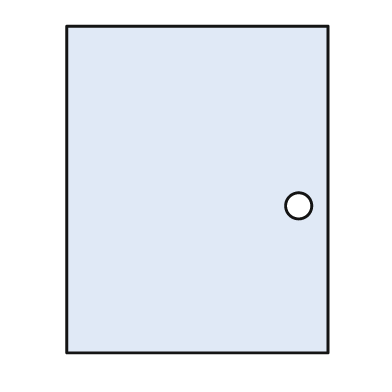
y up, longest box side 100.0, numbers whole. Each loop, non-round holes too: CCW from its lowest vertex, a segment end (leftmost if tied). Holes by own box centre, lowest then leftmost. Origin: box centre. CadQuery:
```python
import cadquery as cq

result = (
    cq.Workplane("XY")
    .moveTo(-40.0, -50.0)
    .lineTo(40.0, -50.0)
    .lineTo(40.0, 50.0)
    .lineTo(-40.0, 50.0)
    .close()
    .moveTo(31.0, -5.0)
    .circle(4.0)
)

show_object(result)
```